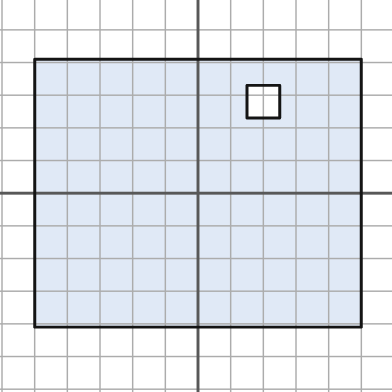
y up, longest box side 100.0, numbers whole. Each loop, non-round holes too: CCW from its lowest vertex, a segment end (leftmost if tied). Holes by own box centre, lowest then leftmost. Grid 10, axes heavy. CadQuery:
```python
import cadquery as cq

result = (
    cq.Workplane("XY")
    .moveTo(-50.0, -41.0)
    .lineTo(50.0, -41.0)
    .lineTo(50.0, 41.0)
    .lineTo(-50.0, 41.0)
    .close()
    .moveTo(15.0, 23.0)
    .lineTo(25.0, 23.0)
    .lineTo(25.0, 33.0)
    .lineTo(15.0, 33.0)
    .close()
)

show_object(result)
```